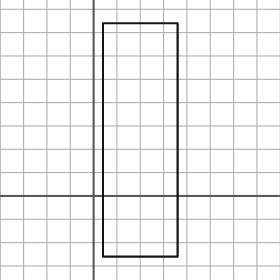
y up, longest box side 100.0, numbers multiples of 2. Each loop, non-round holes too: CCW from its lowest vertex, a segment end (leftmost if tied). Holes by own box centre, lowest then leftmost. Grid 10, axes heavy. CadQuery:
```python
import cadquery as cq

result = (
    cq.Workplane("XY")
    .moveTo(4.0, -26.0)
    .lineTo(36.0, -26.0)
    .lineTo(36.0, 74.0)
    .lineTo(4.0, 74.0)
    .close()
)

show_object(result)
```